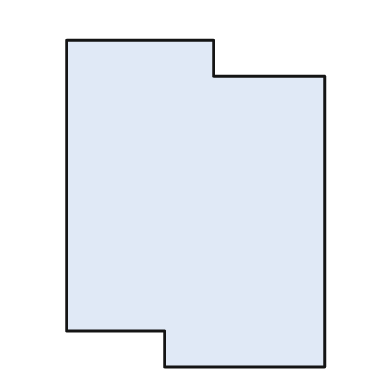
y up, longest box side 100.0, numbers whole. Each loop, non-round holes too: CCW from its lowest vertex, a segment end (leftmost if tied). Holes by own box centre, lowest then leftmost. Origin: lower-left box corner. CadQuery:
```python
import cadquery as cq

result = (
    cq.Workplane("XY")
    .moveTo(30.0, 0.0)
    .lineTo(79.0, 0.0)
    .lineTo(79.0, 89.0)
    .lineTo(45.0, 89.0)
    .lineTo(45.0, 100.0)
    .lineTo(0.0, 100.0)
    .lineTo(0.0, 11.0)
    .lineTo(30.0, 11.0)
    .close()
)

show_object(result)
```